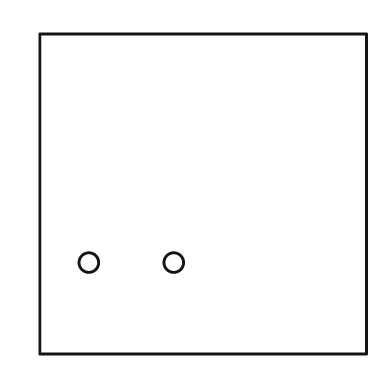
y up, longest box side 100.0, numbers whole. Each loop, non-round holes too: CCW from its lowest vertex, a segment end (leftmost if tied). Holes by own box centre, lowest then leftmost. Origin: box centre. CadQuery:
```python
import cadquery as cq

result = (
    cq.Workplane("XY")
    .moveTo(-50.0, -49.0)
    .lineTo(50.0, -49.0)
    .lineTo(50.0, 49.0)
    .lineTo(-50.0, 49.0)
    .close()
    .moveTo(-35.0, -21.0)
    .circle(3.0)
    .moveTo(-9.0, -21.0)
    .circle(3.0)
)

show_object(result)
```